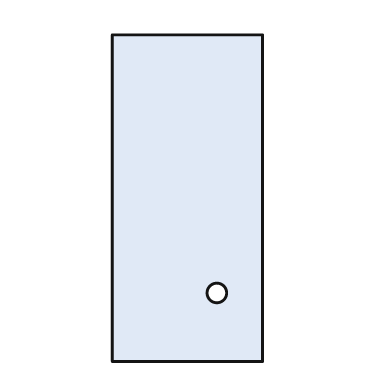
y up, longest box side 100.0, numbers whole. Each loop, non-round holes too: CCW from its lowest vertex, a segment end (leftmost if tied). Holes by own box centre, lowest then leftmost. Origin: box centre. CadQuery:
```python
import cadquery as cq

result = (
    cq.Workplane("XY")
    .moveTo(-23.0, -50.0)
    .lineTo(23.0, -50.0)
    .lineTo(23.0, 50.0)
    .lineTo(-23.0, 50.0)
    .close()
    .moveTo(9.0, -29.0)
    .circle(3.0)
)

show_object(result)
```